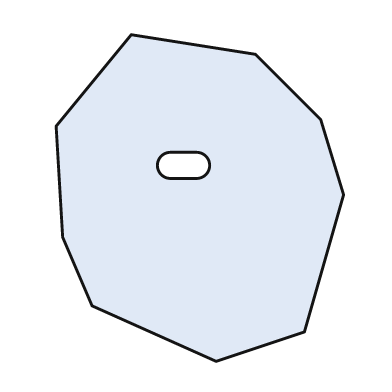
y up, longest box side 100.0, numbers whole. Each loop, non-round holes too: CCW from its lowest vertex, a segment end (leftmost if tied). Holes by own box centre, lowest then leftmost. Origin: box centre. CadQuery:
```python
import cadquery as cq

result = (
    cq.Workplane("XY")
    .moveTo(5.0, -50.0)
    .lineTo(32.0, -41.0)
    .lineTo(44.0, 1.0)
    .lineTo(37.0, 24.0)
    .lineTo(17.0, 44.0)
    .lineTo(-21.0, 50.0)
    .lineTo(-44.0, 22.0)
    .lineTo(-42.0, -12.0)
    .lineTo(-33.0, -33.0)
    .close()
    .moveTo(-9.0, 6.0)
    .lineTo(-1.0, 6.0)
    .threePointArc((3.0, 10.0), (-1.0, 14.0))
    .lineTo(-9.0, 14.0)
    .threePointArc((-13.0, 10.0), (-9.0, 6.0))
    .close()
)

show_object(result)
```